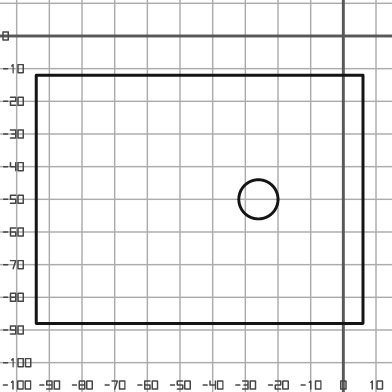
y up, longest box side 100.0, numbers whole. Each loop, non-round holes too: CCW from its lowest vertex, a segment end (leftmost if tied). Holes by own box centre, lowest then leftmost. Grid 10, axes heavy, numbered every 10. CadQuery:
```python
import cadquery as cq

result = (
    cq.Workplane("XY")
    .moveTo(-94.0, -88.0)
    .lineTo(6.0, -88.0)
    .lineTo(6.0, -12.0)
    .lineTo(-94.0, -12.0)
    .close()
    .moveTo(-26.0, -50.0)
    .circle(6.0)
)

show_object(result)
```